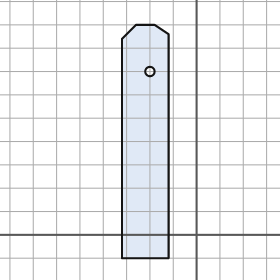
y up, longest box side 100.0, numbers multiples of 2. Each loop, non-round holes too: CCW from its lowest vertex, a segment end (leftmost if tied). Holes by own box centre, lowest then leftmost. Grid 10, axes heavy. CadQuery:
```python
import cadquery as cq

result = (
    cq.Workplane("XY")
    .moveTo(-32.0, -10.0)
    .lineTo(-12.0, -10.0)
    .lineTo(-12.0, 86.0)
    .lineTo(-18.0, 90.0)
    .lineTo(-26.0, 90.0)
    .lineTo(-32.0, 84.0)
    .close()
    .moveTo(-20.0, 70.0)
    .circle(2.0)
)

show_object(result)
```